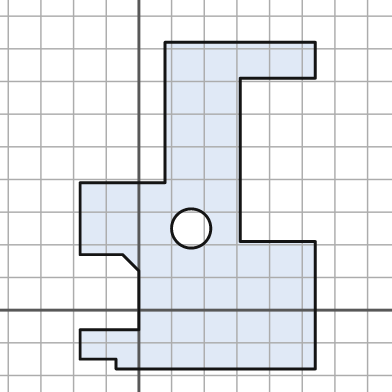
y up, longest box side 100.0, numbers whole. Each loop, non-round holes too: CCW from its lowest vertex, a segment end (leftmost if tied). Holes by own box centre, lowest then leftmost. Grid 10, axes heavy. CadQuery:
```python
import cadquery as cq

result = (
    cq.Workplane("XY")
    .moveTo(-7.0, -18.0)
    .lineTo(54.0, -18.0)
    .lineTo(54.0, 21.0)
    .lineTo(31.0, 21.0)
    .lineTo(31.0, 71.0)
    .lineTo(54.0, 71.0)
    .lineTo(54.0, 82.0)
    .lineTo(8.0, 82.0)
    .lineTo(8.0, 39.0)
    .lineTo(-18.0, 39.0)
    .lineTo(-18.0, 17.0)
    .lineTo(-5.0, 17.0)
    .lineTo(0.0, 12.0)
    .lineTo(0.0, -6.0)
    .lineTo(-18.0, -6.0)
    .lineTo(-18.0, -15.0)
    .lineTo(-7.0, -15.0)
    .close()
    .moveTo(16.0, 25.0)
    .circle(6.0)
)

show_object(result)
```